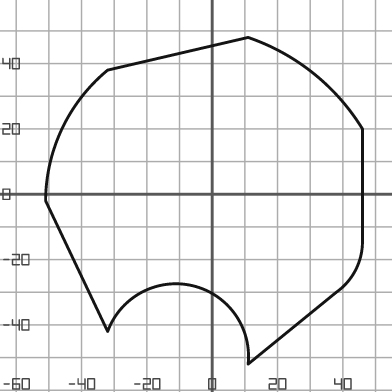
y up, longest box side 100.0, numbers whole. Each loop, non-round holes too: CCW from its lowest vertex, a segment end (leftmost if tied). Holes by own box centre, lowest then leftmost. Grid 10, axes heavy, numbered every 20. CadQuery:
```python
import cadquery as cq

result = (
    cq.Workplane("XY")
    .moveTo(11.0, -52.0)
    .lineTo(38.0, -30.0)
    .threePointArc((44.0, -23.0), (46.0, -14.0))
    .lineTo(46.0, 20.0)
    .threePointArc((31.0, 37.0), (11.0, 48.0))
    .lineTo(-32.0, 38.0)
    .threePointArc((-46.0, 20.0), (-51.0, -2.0))
    .lineTo(-32.0, -42.0)
    .threePointArc((-6.0, -28.0), (11.0, -52.0))
    .close()
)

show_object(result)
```